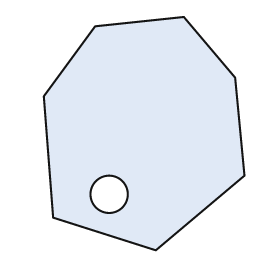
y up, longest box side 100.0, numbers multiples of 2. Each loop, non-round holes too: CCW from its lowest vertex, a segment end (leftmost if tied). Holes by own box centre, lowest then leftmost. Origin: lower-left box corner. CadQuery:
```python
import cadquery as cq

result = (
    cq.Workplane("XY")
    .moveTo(48.0, 0.0)
    .lineTo(86.0, 32.0)
    .lineTo(82.0, 74.0)
    .lineTo(60.0, 100.0)
    .lineTo(22.0, 96.0)
    .lineTo(0.0, 66.0)
    .lineTo(4.0, 14.0)
    .close()
    .moveTo(28.0, 24.0)
    .circle(8.0)
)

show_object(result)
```